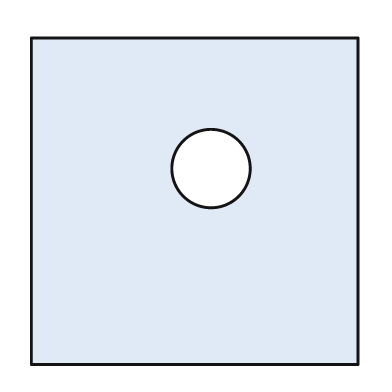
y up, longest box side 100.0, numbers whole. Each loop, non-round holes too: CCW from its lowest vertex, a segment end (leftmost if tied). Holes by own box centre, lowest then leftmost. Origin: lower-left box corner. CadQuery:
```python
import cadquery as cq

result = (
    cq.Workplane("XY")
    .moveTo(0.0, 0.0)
    .lineTo(100.0, 0.0)
    .lineTo(100.0, 100.0)
    .lineTo(0.0, 100.0)
    .close()
    .moveTo(55.0, 60.0)
    .circle(12.0)
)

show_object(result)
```